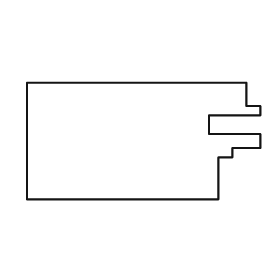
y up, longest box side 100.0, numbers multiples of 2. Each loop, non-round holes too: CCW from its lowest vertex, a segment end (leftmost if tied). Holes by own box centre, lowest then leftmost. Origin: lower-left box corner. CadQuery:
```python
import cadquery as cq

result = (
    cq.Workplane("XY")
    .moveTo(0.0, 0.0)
    .lineTo(82.0, 0.0)
    .lineTo(82.0, 18.0)
    .lineTo(88.0, 18.0)
    .lineTo(88.0, 22.0)
    .lineTo(100.0, 22.0)
    .lineTo(100.0, 28.0)
    .lineTo(78.0, 28.0)
    .lineTo(78.0, 36.0)
    .lineTo(100.0, 36.0)
    .lineTo(100.0, 40.0)
    .lineTo(94.0, 40.0)
    .lineTo(94.0, 50.0)
    .lineTo(0.0, 50.0)
    .close()
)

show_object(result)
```